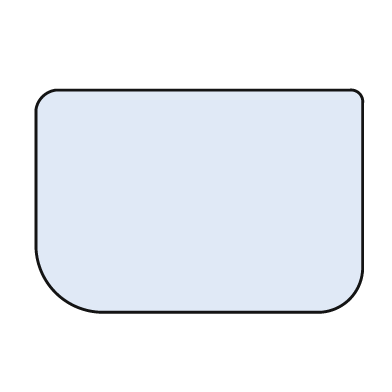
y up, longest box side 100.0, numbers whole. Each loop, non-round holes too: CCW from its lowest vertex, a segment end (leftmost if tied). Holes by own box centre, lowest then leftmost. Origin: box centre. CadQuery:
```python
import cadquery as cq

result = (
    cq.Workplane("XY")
    .moveTo(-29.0, -34.0)
    .lineTo(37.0, -34.0)
    .threePointArc((46.0, -30.0), (50.0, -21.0))
    .lineTo(50.0, 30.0)
    .threePointArc((49.0, 33.0), (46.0, 34.0))
    .lineTo(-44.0, 34.0)
    .threePointArc((-48.0, 32.0), (-50.0, 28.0))
    .lineTo(-50.0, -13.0)
    .threePointArc((-44.0, -28.0), (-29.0, -34.0))
    .close()
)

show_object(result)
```